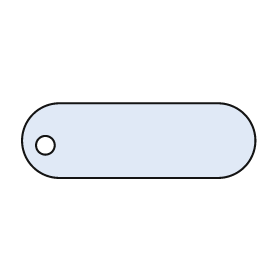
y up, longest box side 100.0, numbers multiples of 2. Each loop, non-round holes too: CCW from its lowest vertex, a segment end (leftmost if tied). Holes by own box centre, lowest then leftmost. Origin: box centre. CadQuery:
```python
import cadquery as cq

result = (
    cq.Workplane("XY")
    .moveTo(-34.0, -16.0)
    .lineTo(34.0, -16.0)
    .threePointArc((50.0, 0.0), (34.0, 16.0))
    .lineTo(-34.0, 16.0)
    .threePointArc((-50.0, 0.0), (-34.0, -16.0))
    .close()
    .moveTo(-40.0, -2.0)
    .circle(4.0)
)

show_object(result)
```